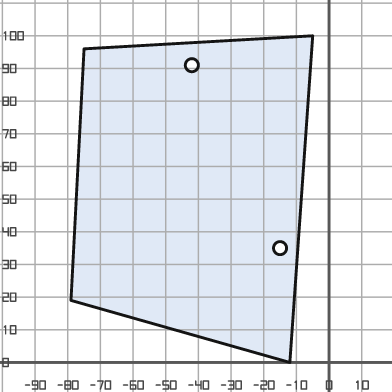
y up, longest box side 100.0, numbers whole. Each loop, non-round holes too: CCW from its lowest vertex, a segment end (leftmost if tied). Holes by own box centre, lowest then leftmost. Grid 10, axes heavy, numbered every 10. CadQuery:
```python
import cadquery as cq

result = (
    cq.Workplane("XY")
    .moveTo(-12.0, 0.0)
    .lineTo(-5.0, 100.0)
    .lineTo(-75.0, 96.0)
    .lineTo(-79.0, 19.0)
    .close()
    .moveTo(-15.0, 35.0)
    .circle(2.0)
    .moveTo(-42.0, 91.0)
    .circle(2.0)
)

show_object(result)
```